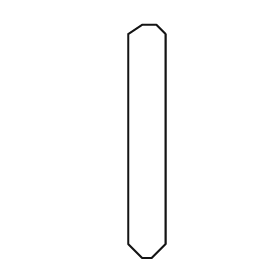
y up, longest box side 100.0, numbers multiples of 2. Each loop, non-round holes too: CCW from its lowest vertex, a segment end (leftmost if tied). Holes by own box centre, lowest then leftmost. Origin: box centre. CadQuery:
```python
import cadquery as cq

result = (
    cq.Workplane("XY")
    .moveTo(-2.0, -50.0)
    .lineTo(2.0, -50.0)
    .lineTo(8.0, -44.0)
    .lineTo(8.0, 46.0)
    .lineTo(4.0, 50.0)
    .lineTo(-2.0, 50.0)
    .lineTo(-8.0, 46.0)
    .lineTo(-8.0, -44.0)
    .close()
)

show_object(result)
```